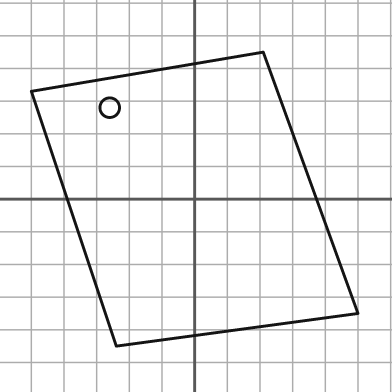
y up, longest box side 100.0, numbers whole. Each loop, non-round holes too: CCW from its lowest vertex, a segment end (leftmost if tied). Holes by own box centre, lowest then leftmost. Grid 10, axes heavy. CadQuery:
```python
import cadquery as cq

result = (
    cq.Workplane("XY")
    .moveTo(-24.0, -45.0)
    .lineTo(50.0, -35.0)
    .lineTo(21.0, 45.0)
    .lineTo(-50.0, 33.0)
    .close()
    .moveTo(-26.0, 28.0)
    .circle(3.0)
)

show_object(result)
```